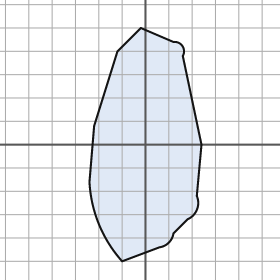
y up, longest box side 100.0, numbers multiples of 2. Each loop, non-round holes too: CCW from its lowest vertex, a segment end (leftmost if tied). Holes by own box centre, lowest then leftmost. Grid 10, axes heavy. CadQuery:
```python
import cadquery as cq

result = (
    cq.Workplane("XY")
    .moveTo(-10.0, -50.0)
    .lineTo(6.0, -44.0)
    .threePointArc((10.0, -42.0), (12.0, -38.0))
    .lineTo(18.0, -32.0)
    .threePointArc((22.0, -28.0), (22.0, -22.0))
    .lineTo(24.0, 0.0)
    .lineTo(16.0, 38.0)
    .threePointArc((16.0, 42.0), (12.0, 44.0))
    .lineTo(-2.0, 50.0)
    .lineTo(-12.0, 40.0)
    .lineTo(-22.0, 8.0)
    .lineTo(-24.0, -16.0)
    .threePointArc((-20.0, -34.0), (-10.0, -50.0))
    .close()
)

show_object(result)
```